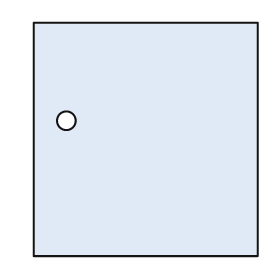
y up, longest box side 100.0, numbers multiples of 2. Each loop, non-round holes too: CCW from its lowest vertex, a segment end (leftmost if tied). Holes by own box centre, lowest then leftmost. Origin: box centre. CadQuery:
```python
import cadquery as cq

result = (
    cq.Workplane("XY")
    .moveTo(-48.0, -50.0)
    .lineTo(48.0, -50.0)
    .lineTo(48.0, 50.0)
    .lineTo(-48.0, 50.0)
    .close()
    .moveTo(-34.0, 8.0)
    .circle(4.0)
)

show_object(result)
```